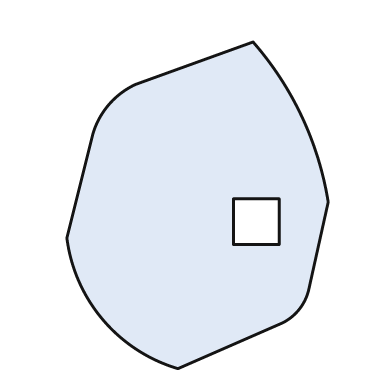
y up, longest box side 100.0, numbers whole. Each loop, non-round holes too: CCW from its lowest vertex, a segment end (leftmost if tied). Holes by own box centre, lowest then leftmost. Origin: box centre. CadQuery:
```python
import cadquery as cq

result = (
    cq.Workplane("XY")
    .moveTo(-6.0, -50.0)
    .lineTo(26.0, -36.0)
    .threePointArc((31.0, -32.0), (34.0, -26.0))
    .lineTo(40.0, 1.0)
    .threePointArc((32.0, 27.0), (17.0, 50.0))
    .lineTo(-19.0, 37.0)
    .threePointArc((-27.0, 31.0), (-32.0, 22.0))
    .lineTo(-40.0, -10.0)
    .threePointArc((-29.0, -35.0), (-6.0, -50.0))
    .close()
    .moveTo(11.0, -12.0)
    .lineTo(25.0, -12.0)
    .lineTo(25.0, 2.0)
    .lineTo(11.0, 2.0)
    .close()
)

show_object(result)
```